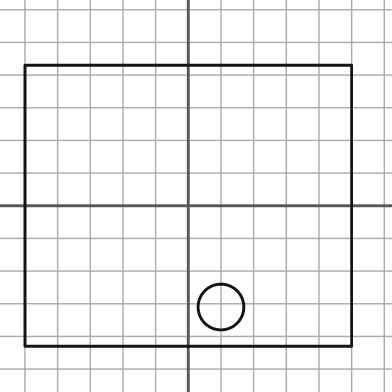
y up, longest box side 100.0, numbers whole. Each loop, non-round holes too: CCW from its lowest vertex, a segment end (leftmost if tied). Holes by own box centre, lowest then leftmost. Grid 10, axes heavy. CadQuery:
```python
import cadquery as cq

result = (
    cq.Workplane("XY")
    .moveTo(-50.0, -43.0)
    .lineTo(50.0, -43.0)
    .lineTo(50.0, 43.0)
    .lineTo(-50.0, 43.0)
    .close()
    .moveTo(10.0, -31.0)
    .circle(7.0)
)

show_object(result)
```